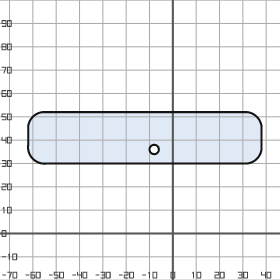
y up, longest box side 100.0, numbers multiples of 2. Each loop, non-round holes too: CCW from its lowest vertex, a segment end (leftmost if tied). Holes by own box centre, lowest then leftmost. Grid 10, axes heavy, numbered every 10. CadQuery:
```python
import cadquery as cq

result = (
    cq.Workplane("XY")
    .moveTo(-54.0, 30.0)
    .lineTo(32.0, 30.0)
    .threePointArc((36.0, 32.0), (38.0, 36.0))
    .lineTo(38.0, 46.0)
    .threePointArc((36.0, 50.0), (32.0, 52.0))
    .lineTo(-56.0, 52.0)
    .threePointArc((-60.0, 50.0), (-62.0, 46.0))
    .lineTo(-62.0, 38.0)
    .threePointArc((-60.0, 32.0), (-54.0, 30.0))
    .close()
    .moveTo(-8.0, 36.0)
    .circle(2.0)
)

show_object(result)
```